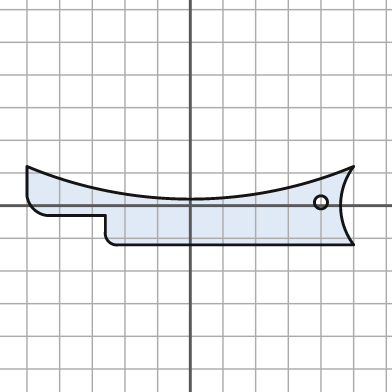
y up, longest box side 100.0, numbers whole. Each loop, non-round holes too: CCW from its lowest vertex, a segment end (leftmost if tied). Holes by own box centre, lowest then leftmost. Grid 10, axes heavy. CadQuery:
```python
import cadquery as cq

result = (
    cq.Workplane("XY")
    .moveTo(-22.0, -12.0)
    .lineTo(50.0, -12.0)
    .threePointArc((46.0, 0.0), (50.0, 12.0))
    .threePointArc((0.0, 2.0), (-50.0, 12.0))
    .lineTo(-50.0, 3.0)
    .threePointArc((-48.0, -1.0), (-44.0, -3.0))
    .lineTo(-26.0, -3.0)
    .lineTo(-26.0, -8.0)
    .threePointArc((-25.0, -11.0), (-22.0, -12.0))
    .close()
    .moveTo(40.0, 1.0)
    .circle(2.0)
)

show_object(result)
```